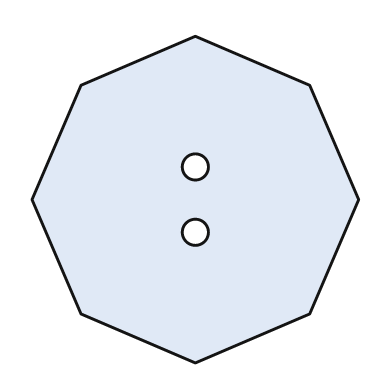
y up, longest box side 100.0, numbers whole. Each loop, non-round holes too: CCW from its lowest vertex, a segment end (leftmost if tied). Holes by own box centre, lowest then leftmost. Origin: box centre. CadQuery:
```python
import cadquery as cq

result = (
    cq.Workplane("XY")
    .moveTo(0.0, -50.0)
    .lineTo(35.0, -35.0)
    .lineTo(50.0, 0.0)
    .lineTo(35.0, 35.0)
    .lineTo(0.0, 50.0)
    .lineTo(-35.0, 35.0)
    .lineTo(-50.0, 0.0)
    .lineTo(-35.0, -35.0)
    .close()
    .moveTo(0.0, -10.0)
    .circle(4.0)
    .moveTo(0.0, 10.0)
    .circle(4.0)
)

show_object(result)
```